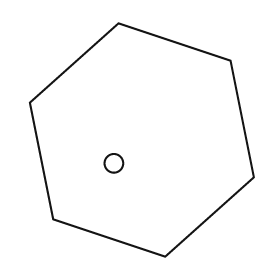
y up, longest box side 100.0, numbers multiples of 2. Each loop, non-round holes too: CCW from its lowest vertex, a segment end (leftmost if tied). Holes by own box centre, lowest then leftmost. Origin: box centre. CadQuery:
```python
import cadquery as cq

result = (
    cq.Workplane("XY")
    .moveTo(10.0, -50.0)
    .lineTo(48.0, -16.0)
    .lineTo(38.0, 34.0)
    .lineTo(-10.0, 50.0)
    .lineTo(-48.0, 16.0)
    .lineTo(-38.0, -34.0)
    .close()
    .moveTo(-12.0, -10.0)
    .circle(4.0)
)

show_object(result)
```